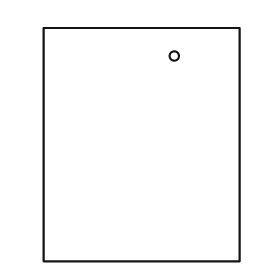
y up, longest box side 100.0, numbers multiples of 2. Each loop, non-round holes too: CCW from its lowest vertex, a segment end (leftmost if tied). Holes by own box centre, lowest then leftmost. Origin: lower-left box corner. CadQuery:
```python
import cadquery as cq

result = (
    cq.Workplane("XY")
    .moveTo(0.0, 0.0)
    .lineTo(84.0, 0.0)
    .lineTo(84.0, 100.0)
    .lineTo(0.0, 100.0)
    .close()
    .moveTo(56.0, 88.0)
    .circle(2.0)
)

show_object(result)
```